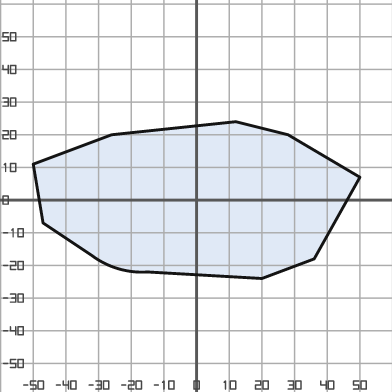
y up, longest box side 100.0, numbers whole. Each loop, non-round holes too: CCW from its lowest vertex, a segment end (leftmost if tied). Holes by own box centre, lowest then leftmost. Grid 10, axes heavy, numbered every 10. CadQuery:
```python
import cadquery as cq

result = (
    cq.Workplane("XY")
    .moveTo(20.0, -24.0)
    .lineTo(36.0, -18.0)
    .lineTo(50.0, 7.0)
    .lineTo(28.0, 20.0)
    .lineTo(12.0, 24.0)
    .lineTo(-26.0, 20.0)
    .lineTo(-50.0, 11.0)
    .lineTo(-47.0, -7.0)
    .lineTo(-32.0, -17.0)
    .threePointArc((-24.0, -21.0), (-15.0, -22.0))
    .close()
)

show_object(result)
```